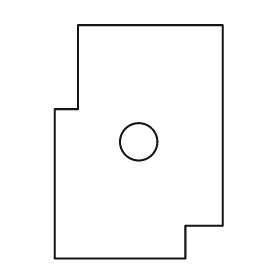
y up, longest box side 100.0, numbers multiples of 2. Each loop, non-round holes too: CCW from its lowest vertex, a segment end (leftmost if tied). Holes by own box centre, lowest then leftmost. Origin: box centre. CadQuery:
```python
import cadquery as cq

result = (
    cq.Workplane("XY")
    .moveTo(-36.0, -50.0)
    .lineTo(20.0, -50.0)
    .lineTo(20.0, -36.0)
    .lineTo(36.0, -36.0)
    .lineTo(36.0, 50.0)
    .lineTo(-26.0, 50.0)
    .lineTo(-26.0, 14.0)
    .lineTo(-36.0, 14.0)
    .close()
    .moveTo(0.0, 0.0)
    .circle(8.0)
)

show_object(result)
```